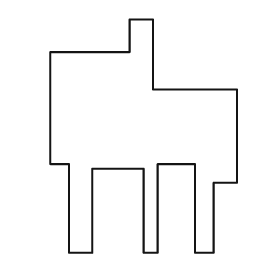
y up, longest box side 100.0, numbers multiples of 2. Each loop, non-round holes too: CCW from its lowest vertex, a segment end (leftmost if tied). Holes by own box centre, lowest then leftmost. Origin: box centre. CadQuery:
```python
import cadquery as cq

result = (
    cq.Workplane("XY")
    .moveTo(-32.0, -50.0)
    .lineTo(-22.0, -50.0)
    .lineTo(-22.0, -14.0)
    .lineTo(0.0, -14.0)
    .lineTo(0.0, -50.0)
    .lineTo(6.0, -50.0)
    .lineTo(6.0, -12.0)
    .lineTo(22.0, -12.0)
    .lineTo(22.0, -50.0)
    .lineTo(30.0, -50.0)
    .lineTo(30.0, -20.0)
    .lineTo(40.0, -20.0)
    .lineTo(40.0, 20.0)
    .lineTo(4.0, 20.0)
    .lineTo(4.0, 50.0)
    .lineTo(-6.0, 50.0)
    .lineTo(-6.0, 36.0)
    .lineTo(-40.0, 36.0)
    .lineTo(-40.0, -12.0)
    .lineTo(-32.0, -12.0)
    .close()
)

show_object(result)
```